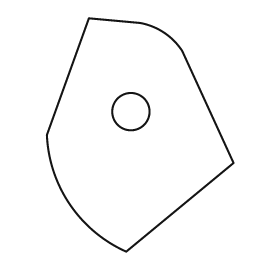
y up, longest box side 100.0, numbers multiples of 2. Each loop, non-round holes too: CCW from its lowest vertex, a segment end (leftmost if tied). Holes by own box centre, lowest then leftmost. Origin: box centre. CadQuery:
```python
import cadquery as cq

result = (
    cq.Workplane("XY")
    .moveTo(-6.0, -50.0)
    .lineTo(40.0, -12.0)
    .lineTo(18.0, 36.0)
    .threePointArc((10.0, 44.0), (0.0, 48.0))
    .lineTo(-22.0, 50.0)
    .lineTo(-40.0, 0.0)
    .threePointArc((-30.0, -30.0), (-6.0, -50.0))
    .close()
    .moveTo(-4.0, 10.0)
    .circle(8.0)
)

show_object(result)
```